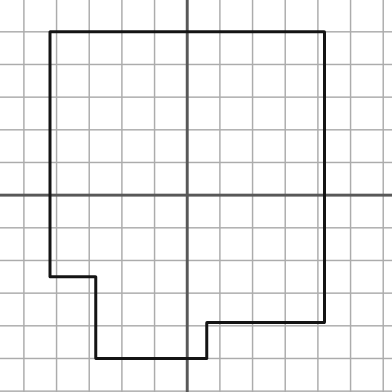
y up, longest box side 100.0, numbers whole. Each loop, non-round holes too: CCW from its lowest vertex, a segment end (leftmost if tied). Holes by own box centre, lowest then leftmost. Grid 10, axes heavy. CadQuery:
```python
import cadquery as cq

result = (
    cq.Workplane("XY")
    .moveTo(-28.0, -50.0)
    .lineTo(6.0, -50.0)
    .lineTo(6.0, -39.0)
    .lineTo(42.0, -39.0)
    .lineTo(42.0, 50.0)
    .lineTo(-42.0, 50.0)
    .lineTo(-42.0, -25.0)
    .lineTo(-28.0, -25.0)
    .close()
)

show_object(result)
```